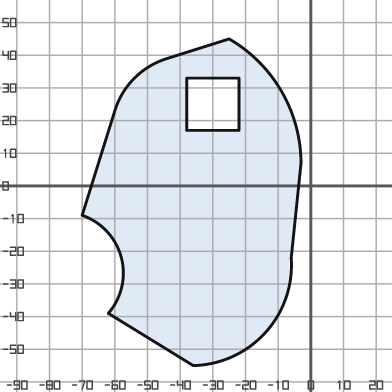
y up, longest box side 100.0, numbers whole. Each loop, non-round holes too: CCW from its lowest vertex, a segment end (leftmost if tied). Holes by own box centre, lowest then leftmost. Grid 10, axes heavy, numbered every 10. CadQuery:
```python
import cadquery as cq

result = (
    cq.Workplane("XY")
    .moveTo(-36.0, -55.0)
    .threePointArc((-14.0, -45.0), (-6.0, -22.0))
    .lineTo(-3.0, 7.0)
    .threePointArc((-9.0, 29.0), (-25.0, 45.0))
    .lineTo(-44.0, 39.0)
    .threePointArc((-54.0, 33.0), (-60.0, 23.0))
    .lineTo(-70.0, -9.0)
    .threePointArc((-58.0, -22.0), (-62.0, -39.0))
    .close()
    .moveTo(-38.0, 17.0)
    .lineTo(-22.0, 17.0)
    .lineTo(-22.0, 33.0)
    .lineTo(-38.0, 33.0)
    .close()
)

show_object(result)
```